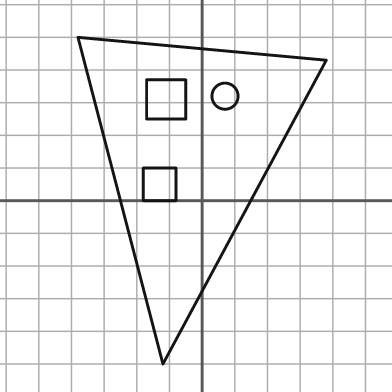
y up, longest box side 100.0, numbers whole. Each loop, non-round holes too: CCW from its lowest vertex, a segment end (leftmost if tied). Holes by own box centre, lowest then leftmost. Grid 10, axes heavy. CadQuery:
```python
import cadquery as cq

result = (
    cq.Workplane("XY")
    .moveTo(-12.0, -50.0)
    .lineTo(38.0, 43.0)
    .lineTo(-38.0, 50.0)
    .close()
    .moveTo(-18.0, 0.0)
    .lineTo(-8.0, 0.0)
    .lineTo(-8.0, 10.0)
    .lineTo(-18.0, 10.0)
    .close()
    .moveTo(-17.0, 25.0)
    .lineTo(-5.0, 25.0)
    .lineTo(-5.0, 37.0)
    .lineTo(-17.0, 37.0)
    .close()
    .moveTo(7.0, 32.0)
    .circle(4.0)
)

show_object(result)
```